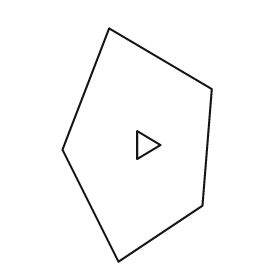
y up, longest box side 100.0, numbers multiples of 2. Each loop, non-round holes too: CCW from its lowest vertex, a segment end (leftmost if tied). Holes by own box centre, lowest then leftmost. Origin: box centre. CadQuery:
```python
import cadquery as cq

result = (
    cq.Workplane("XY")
    .moveTo(-8.0, -50.0)
    .lineTo(28.0, -26.0)
    .lineTo(32.0, 24.0)
    .lineTo(-12.0, 50.0)
    .lineTo(-32.0, -2.0)
    .close()
    .moveTo(0.0, -6.0)
    .lineTo(10.0, 0.0)
    .lineTo(0.0, 6.0)
    .close()
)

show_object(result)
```